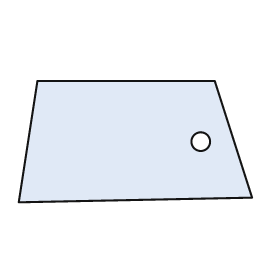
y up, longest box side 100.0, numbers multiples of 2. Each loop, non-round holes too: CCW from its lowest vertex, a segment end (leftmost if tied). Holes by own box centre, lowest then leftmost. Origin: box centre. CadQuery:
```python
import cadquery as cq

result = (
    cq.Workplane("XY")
    .moveTo(-50.0, -26.0)
    .lineTo(50.0, -24.0)
    .lineTo(34.0, 26.0)
    .lineTo(-42.0, 26.0)
    .close()
    .moveTo(28.0, 0.0)
    .circle(4.0)
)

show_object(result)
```